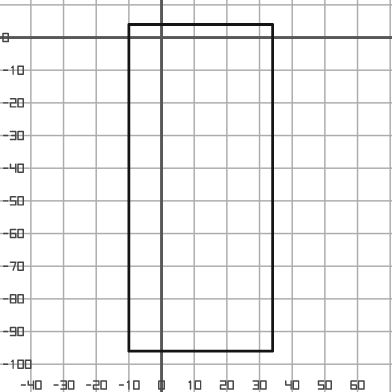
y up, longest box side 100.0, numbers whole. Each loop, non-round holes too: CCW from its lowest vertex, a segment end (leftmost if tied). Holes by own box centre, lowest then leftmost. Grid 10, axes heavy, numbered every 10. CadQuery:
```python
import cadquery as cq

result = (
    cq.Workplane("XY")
    .moveTo(-10.0, -96.0)
    .lineTo(34.0, -96.0)
    .lineTo(34.0, 4.0)
    .lineTo(-10.0, 4.0)
    .close()
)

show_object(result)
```